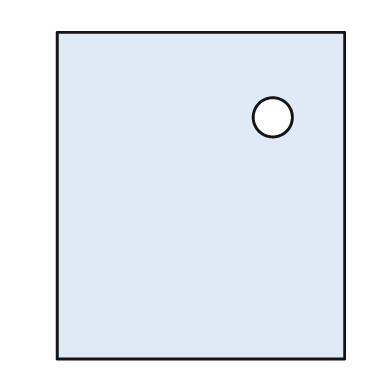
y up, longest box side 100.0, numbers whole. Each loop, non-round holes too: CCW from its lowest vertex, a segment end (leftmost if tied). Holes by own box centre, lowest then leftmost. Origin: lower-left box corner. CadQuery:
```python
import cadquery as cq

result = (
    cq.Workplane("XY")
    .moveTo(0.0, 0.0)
    .lineTo(88.0, 0.0)
    .lineTo(88.0, 100.0)
    .lineTo(0.0, 100.0)
    .close()
    .moveTo(66.0, 74.0)
    .circle(6.0)
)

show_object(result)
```